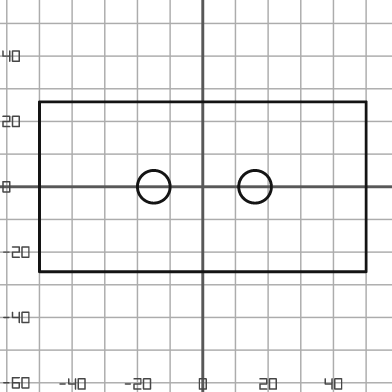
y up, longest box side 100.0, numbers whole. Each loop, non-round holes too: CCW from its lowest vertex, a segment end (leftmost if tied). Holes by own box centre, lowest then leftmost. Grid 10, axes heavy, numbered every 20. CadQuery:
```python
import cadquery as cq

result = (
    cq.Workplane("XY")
    .moveTo(-50.0, -26.0)
    .lineTo(50.0, -26.0)
    .lineTo(50.0, 26.0)
    .lineTo(-50.0, 26.0)
    .close()
    .moveTo(-15.0, 0.0)
    .circle(5.0)
    .moveTo(16.0, 0.0)
    .circle(5.0)
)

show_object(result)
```